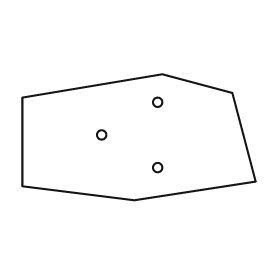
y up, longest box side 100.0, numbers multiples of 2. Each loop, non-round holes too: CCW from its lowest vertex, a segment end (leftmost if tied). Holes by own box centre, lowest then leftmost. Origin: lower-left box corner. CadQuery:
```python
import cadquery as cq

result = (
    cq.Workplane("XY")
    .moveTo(48.0, 0.0)
    .lineTo(100.0, 8.0)
    .lineTo(90.0, 46.0)
    .lineTo(60.0, 54.0)
    .lineTo(0.0, 44.0)
    .lineTo(0.0, 6.0)
    .close()
    .moveTo(58.0, 14.0)
    .circle(2.0)
    .moveTo(34.0, 28.0)
    .circle(2.0)
    .moveTo(58.0, 42.0)
    .circle(2.0)
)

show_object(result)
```